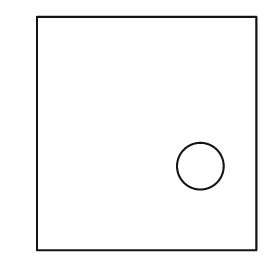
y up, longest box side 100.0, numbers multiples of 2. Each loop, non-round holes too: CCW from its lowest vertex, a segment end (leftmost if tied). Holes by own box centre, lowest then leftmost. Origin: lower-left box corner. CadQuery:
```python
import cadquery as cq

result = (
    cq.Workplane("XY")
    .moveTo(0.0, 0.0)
    .lineTo(94.0, 0.0)
    .lineTo(94.0, 100.0)
    .lineTo(0.0, 100.0)
    .close()
    .moveTo(70.0, 36.0)
    .circle(10.0)
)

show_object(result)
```